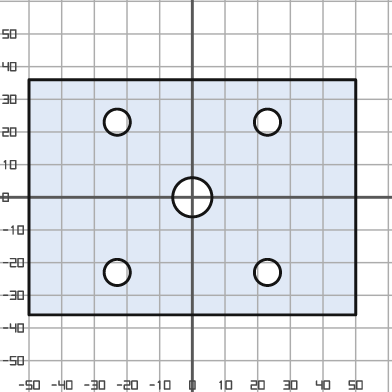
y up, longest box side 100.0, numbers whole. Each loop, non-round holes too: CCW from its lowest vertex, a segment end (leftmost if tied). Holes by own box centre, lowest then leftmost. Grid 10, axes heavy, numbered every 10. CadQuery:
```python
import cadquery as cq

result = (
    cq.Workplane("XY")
    .moveTo(-50.0, -36.0)
    .lineTo(50.0, -36.0)
    .lineTo(50.0, 36.0)
    .lineTo(-50.0, 36.0)
    .close()
    .moveTo(-23.0, -23.0)
    .circle(4.0)
    .moveTo(23.0, -23.0)
    .circle(4.0)
    .moveTo(0.0, 0.0)
    .circle(6.0)
    .moveTo(-23.0, 23.0)
    .circle(4.0)
    .moveTo(23.0, 23.0)
    .circle(4.0)
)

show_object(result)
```